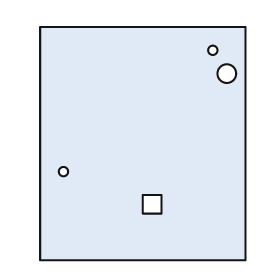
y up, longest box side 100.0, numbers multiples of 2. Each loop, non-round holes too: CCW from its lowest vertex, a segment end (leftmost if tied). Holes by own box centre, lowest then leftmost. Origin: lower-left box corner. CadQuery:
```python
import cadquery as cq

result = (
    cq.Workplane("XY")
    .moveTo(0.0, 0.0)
    .lineTo(88.0, 0.0)
    .lineTo(88.0, 100.0)
    .lineTo(0.0, 100.0)
    .close()
    .moveTo(44.0, 20.0)
    .lineTo(52.0, 20.0)
    .lineTo(52.0, 28.0)
    .lineTo(44.0, 28.0)
    .close()
    .moveTo(10.0, 38.0)
    .circle(2.0)
    .moveTo(80.0, 80.0)
    .circle(4.0)
    .moveTo(74.0, 90.0)
    .circle(2.0)
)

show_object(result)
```